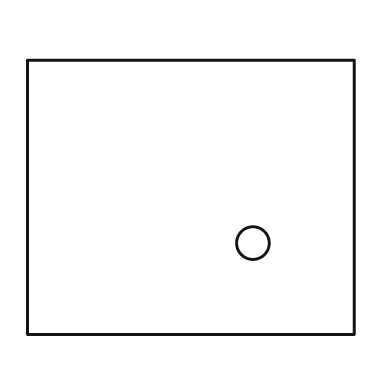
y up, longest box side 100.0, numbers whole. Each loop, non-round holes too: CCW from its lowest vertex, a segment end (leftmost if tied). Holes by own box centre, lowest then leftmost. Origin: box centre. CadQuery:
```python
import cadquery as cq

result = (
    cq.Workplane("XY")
    .moveTo(-50.0, -42.0)
    .lineTo(50.0, -42.0)
    .lineTo(50.0, 42.0)
    .lineTo(-50.0, 42.0)
    .close()
    .moveTo(19.0, -14.0)
    .circle(5.0)
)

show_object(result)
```